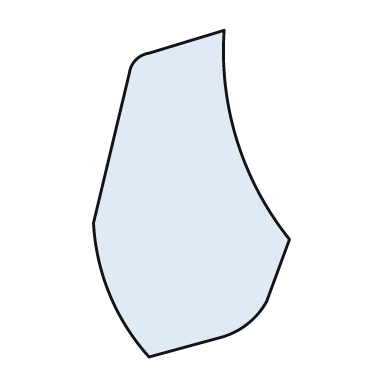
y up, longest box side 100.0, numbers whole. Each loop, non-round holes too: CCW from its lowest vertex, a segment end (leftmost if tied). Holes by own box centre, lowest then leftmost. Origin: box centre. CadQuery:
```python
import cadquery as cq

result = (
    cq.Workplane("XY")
    .moveTo(-13.0, -50.0)
    .lineTo(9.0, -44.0)
    .threePointArc((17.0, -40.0), (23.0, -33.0))
    .lineTo(30.0, -14.0)
    .threePointArc((14.0, 16.0), (10.0, 50.0))
    .lineTo(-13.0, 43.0)
    .threePointArc((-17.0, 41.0), (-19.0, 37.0))
    .lineTo(-30.0, -9.0)
    .threePointArc((-25.0, -31.0), (-13.0, -50.0))
    .close()
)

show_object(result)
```